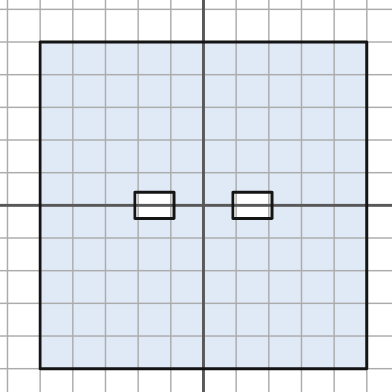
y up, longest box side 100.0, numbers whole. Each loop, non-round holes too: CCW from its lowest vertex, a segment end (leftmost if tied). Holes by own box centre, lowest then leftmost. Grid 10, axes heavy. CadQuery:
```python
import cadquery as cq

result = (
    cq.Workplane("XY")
    .moveTo(-50.0, -50.0)
    .lineTo(50.0, -50.0)
    .lineTo(50.0, 50.0)
    .lineTo(-50.0, 50.0)
    .close()
    .moveTo(-21.0, -4.0)
    .lineTo(-9.0, -4.0)
    .lineTo(-9.0, 4.0)
    .lineTo(-21.0, 4.0)
    .close()
    .moveTo(9.0, -4.0)
    .lineTo(21.0, -4.0)
    .lineTo(21.0, 4.0)
    .lineTo(9.0, 4.0)
    .close()
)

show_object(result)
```